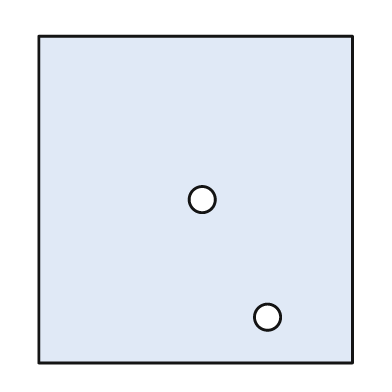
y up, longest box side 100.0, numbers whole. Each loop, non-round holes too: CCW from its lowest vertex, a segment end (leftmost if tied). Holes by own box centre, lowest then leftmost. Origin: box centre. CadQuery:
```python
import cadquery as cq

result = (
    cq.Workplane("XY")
    .moveTo(-48.0, -50.0)
    .lineTo(48.0, -50.0)
    .lineTo(48.0, 50.0)
    .lineTo(-48.0, 50.0)
    .close()
    .moveTo(22.0, -36.0)
    .circle(4.0)
    .moveTo(2.0, 0.0)
    .circle(4.0)
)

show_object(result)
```